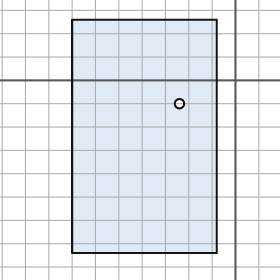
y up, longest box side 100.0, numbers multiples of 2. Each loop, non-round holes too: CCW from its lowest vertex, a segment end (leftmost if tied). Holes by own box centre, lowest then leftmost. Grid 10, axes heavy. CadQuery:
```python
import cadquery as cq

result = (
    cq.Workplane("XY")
    .moveTo(-70.0, -74.0)
    .lineTo(-8.0, -74.0)
    .lineTo(-8.0, 26.0)
    .lineTo(-70.0, 26.0)
    .close()
    .moveTo(-24.0, -10.0)
    .circle(2.0)
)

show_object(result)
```